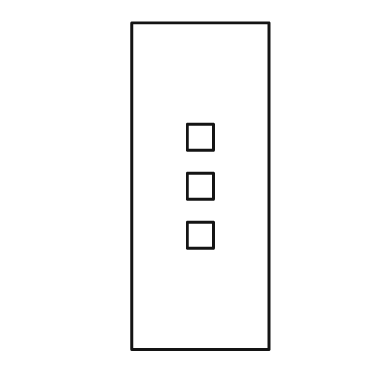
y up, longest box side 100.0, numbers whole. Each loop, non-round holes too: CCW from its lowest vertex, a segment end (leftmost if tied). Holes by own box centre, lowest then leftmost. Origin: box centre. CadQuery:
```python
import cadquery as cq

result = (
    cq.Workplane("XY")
    .moveTo(-21.0, -50.0)
    .lineTo(21.0, -50.0)
    .lineTo(21.0, 50.0)
    .lineTo(-21.0, 50.0)
    .close()
    .moveTo(-4.0, -19.0)
    .lineTo(4.0, -19.0)
    .lineTo(4.0, -11.0)
    .lineTo(-4.0, -11.0)
    .close()
    .moveTo(-4.0, -4.0)
    .lineTo(4.0, -4.0)
    .lineTo(4.0, 4.0)
    .lineTo(-4.0, 4.0)
    .close()
    .moveTo(-4.0, 11.0)
    .lineTo(4.0, 11.0)
    .lineTo(4.0, 19.0)
    .lineTo(-4.0, 19.0)
    .close()
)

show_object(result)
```